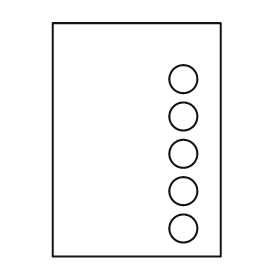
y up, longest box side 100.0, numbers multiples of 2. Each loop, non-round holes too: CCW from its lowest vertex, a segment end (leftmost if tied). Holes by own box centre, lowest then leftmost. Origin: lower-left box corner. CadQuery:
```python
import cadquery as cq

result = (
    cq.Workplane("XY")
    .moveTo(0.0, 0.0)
    .lineTo(72.0, 0.0)
    .lineTo(72.0, 100.0)
    .lineTo(0.0, 100.0)
    .close()
    .moveTo(56.0, 12.0)
    .circle(6.0)
    .moveTo(56.0, 28.0)
    .circle(6.0)
    .moveTo(56.0, 44.0)
    .circle(6.0)
    .moveTo(56.0, 60.0)
    .circle(6.0)
    .moveTo(56.0, 76.0)
    .circle(6.0)
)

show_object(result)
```